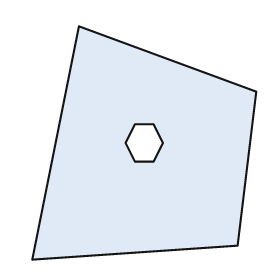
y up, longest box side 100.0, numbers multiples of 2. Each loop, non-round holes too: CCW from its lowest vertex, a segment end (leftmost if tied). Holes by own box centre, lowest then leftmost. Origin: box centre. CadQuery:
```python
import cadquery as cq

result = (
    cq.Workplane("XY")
    .moveTo(-48.0, -50.0)
    .lineTo(40.0, -44.0)
    .lineTo(48.0, 22.0)
    .lineTo(-28.0, 50.0)
    .close()
    .moveTo(-4.0, -8.0)
    .lineTo(4.0, -8.0)
    .lineTo(8.0, 0.0)
    .lineTo(4.0, 8.0)
    .lineTo(-4.0, 8.0)
    .lineTo(-8.0, 0.0)
    .close()
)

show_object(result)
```